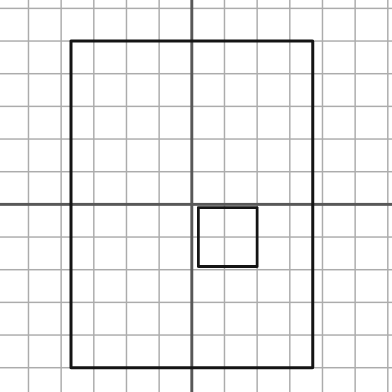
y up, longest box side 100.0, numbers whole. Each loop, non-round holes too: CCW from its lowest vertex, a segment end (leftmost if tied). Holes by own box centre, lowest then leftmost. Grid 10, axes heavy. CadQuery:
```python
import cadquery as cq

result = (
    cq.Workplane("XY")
    .moveTo(-37.0, -50.0)
    .lineTo(37.0, -50.0)
    .lineTo(37.0, 50.0)
    .lineTo(-37.0, 50.0)
    .close()
    .moveTo(2.0, -19.0)
    .lineTo(20.0, -19.0)
    .lineTo(20.0, -1.0)
    .lineTo(2.0, -1.0)
    .close()
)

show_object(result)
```